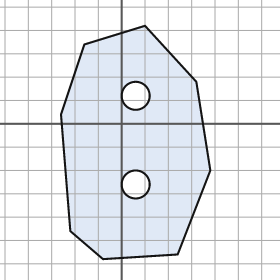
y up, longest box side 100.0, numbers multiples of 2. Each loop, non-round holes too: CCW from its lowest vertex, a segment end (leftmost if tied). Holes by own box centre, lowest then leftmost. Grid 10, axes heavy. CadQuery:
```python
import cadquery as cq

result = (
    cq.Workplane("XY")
    .moveTo(-8.0, -58.0)
    .lineTo(24.0, -56.0)
    .lineTo(38.0, -20.0)
    .lineTo(32.0, 18.0)
    .lineTo(10.0, 42.0)
    .lineTo(-16.0, 34.0)
    .lineTo(-26.0, 4.0)
    .lineTo(-22.0, -46.0)
    .close()
    .moveTo(6.0, -26.0)
    .circle(6.0)
    .moveTo(6.0, 12.0)
    .circle(6.0)
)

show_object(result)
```